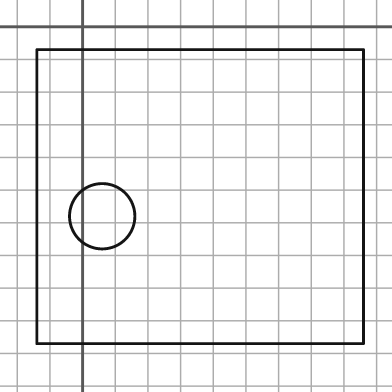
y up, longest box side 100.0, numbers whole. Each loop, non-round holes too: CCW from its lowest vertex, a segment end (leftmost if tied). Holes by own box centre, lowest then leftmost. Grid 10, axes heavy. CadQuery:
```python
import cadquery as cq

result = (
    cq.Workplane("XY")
    .moveTo(-14.0, -97.0)
    .lineTo(86.0, -97.0)
    .lineTo(86.0, -7.0)
    .lineTo(-14.0, -7.0)
    .close()
    .moveTo(6.0, -58.0)
    .circle(10.0)
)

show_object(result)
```